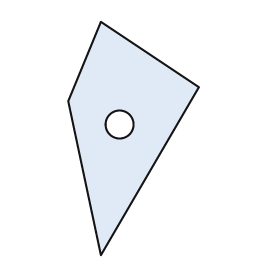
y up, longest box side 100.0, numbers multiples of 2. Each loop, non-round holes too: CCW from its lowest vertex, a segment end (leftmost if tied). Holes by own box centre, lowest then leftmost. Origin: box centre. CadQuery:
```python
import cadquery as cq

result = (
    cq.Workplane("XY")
    .moveTo(-14.0, -50.0)
    .lineTo(28.0, 22.0)
    .lineTo(-14.0, 50.0)
    .lineTo(-28.0, 16.0)
    .close()
    .moveTo(-6.0, 6.0)
    .circle(6.0)
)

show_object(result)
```